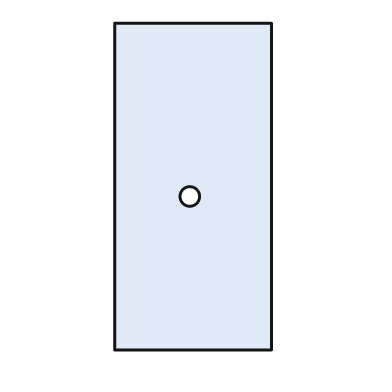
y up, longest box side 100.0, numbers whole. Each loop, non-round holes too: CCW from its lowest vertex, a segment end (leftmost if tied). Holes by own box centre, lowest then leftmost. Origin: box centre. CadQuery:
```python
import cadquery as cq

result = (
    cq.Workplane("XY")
    .moveTo(-24.0, -50.0)
    .lineTo(24.0, -50.0)
    .lineTo(24.0, 50.0)
    .lineTo(-24.0, 50.0)
    .close()
    .moveTo(-1.0, -3.0)
    .circle(3.0)
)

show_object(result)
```